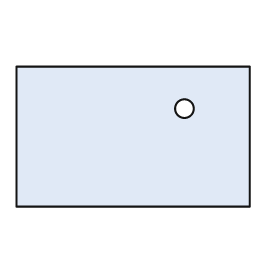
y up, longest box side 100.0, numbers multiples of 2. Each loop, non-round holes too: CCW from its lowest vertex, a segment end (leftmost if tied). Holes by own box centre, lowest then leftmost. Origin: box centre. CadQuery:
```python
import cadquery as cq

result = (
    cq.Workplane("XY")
    .moveTo(-50.0, -30.0)
    .lineTo(50.0, -30.0)
    .lineTo(50.0, 30.0)
    .lineTo(-50.0, 30.0)
    .close()
    .moveTo(22.0, 12.0)
    .circle(4.0)
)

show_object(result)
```